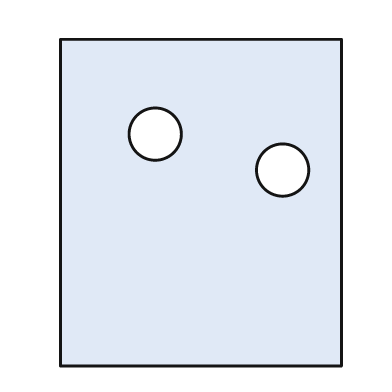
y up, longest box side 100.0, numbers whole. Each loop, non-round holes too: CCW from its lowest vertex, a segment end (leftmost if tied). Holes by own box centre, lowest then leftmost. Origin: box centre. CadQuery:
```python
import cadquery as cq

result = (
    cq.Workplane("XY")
    .moveTo(-43.0, -50.0)
    .lineTo(43.0, -50.0)
    .lineTo(43.0, 50.0)
    .lineTo(-43.0, 50.0)
    .close()
    .moveTo(25.0, 10.0)
    .circle(8.0)
    .moveTo(-14.0, 21.0)
    .circle(8.0)
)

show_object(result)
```